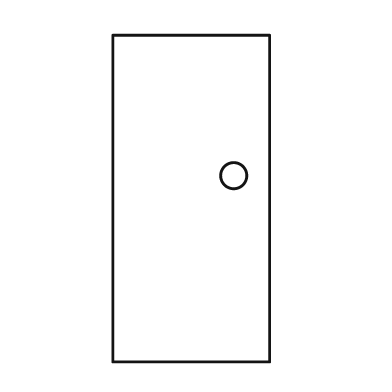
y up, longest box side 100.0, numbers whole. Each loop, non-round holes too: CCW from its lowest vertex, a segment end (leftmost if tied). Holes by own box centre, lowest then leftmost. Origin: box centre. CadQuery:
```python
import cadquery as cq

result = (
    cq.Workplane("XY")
    .moveTo(-24.0, -50.0)
    .lineTo(24.0, -50.0)
    .lineTo(24.0, 50.0)
    .lineTo(-24.0, 50.0)
    .close()
    .moveTo(13.0, 7.0)
    .circle(4.0)
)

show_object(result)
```